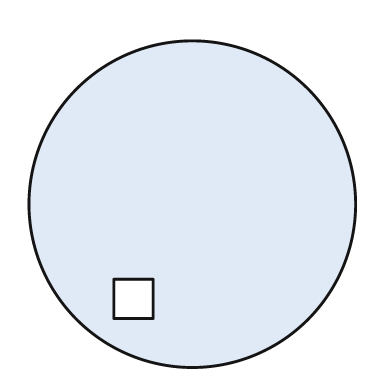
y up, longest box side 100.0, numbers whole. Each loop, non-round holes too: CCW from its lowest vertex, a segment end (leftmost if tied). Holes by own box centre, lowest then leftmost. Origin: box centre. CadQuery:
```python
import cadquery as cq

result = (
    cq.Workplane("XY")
    .moveTo(0.0, 0.0)
    .circle(50.0)
    .moveTo(-24.0, -35.0)
    .lineTo(-12.0, -35.0)
    .lineTo(-12.0, -23.0)
    .lineTo(-24.0, -23.0)
    .close()
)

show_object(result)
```